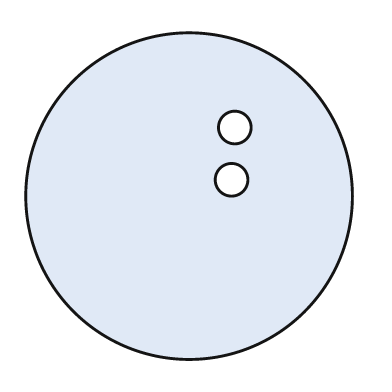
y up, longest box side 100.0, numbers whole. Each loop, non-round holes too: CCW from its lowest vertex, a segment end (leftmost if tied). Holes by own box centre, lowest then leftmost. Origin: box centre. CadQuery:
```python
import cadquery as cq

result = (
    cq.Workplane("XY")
    .moveTo(0.0, 0.0)
    .circle(50.0)
    .moveTo(13.0, 5.0)
    .circle(5.0)
    .moveTo(14.0, 21.0)
    .circle(5.0)
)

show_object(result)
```